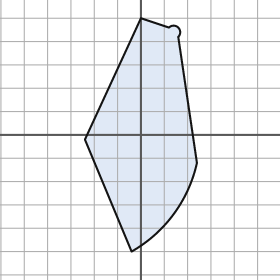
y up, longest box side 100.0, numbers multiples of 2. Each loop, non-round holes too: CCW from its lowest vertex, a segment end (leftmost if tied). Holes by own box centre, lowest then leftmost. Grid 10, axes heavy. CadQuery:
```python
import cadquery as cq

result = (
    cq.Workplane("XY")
    .moveTo(-4.0, -50.0)
    .threePointArc((14.0, -34.0), (24.0, -12.0))
    .lineTo(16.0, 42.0)
    .threePointArc((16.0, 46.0), (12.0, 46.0))
    .lineTo(0.0, 50.0)
    .lineTo(-24.0, -2.0)
    .close()
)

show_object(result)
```